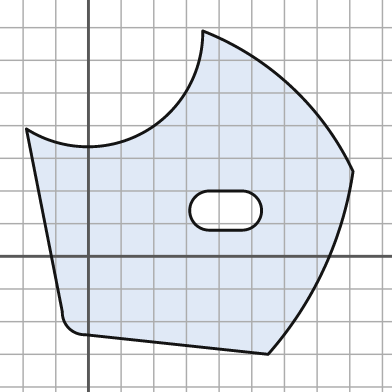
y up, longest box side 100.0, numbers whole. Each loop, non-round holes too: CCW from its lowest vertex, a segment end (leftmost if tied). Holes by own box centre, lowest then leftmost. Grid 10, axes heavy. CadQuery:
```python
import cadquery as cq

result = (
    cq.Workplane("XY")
    .moveTo(55.0, -30.0)
    .threePointArc((72.0, -4.0), (81.0, 26.0))
    .threePointArc((62.0, 52.0), (35.0, 69.0))
    .threePointArc((17.0, 38.0), (-19.0, 39.0))
    .lineTo(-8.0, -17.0)
    .threePointArc((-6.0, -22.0), (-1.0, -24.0))
    .close()
    .moveTo(37.0, 8.0)
    .lineTo(47.0, 8.0)
    .threePointArc((53.0, 14.0), (47.0, 20.0))
    .lineTo(37.0, 20.0)
    .threePointArc((31.0, 14.0), (37.0, 8.0))
    .close()
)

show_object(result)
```